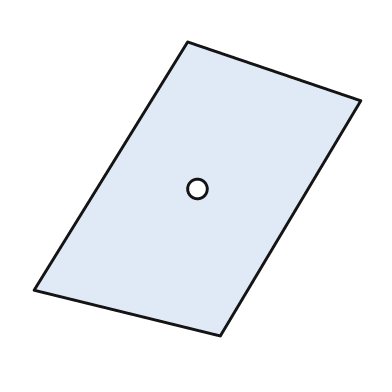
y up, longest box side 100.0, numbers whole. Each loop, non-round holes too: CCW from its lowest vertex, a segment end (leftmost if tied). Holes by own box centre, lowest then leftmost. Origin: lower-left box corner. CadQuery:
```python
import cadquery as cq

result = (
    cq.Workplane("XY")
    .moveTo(57.0, 0.0)
    .lineTo(100.0, 72.0)
    .lineTo(47.0, 90.0)
    .lineTo(0.0, 14.0)
    .close()
    .moveTo(50.0, 45.0)
    .circle(3.0)
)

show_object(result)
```